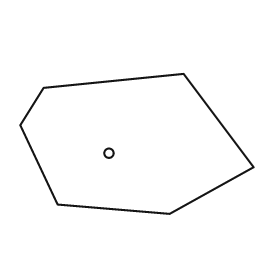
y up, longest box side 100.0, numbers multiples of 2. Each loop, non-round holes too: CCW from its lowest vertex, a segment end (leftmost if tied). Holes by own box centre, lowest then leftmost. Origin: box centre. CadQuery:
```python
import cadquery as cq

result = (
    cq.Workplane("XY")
    .moveTo(14.0, -30.0)
    .lineTo(50.0, -10.0)
    .lineTo(20.0, 30.0)
    .lineTo(-40.0, 24.0)
    .lineTo(-50.0, 8.0)
    .lineTo(-34.0, -26.0)
    .close()
    .moveTo(-12.0, -4.0)
    .circle(2.0)
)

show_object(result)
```